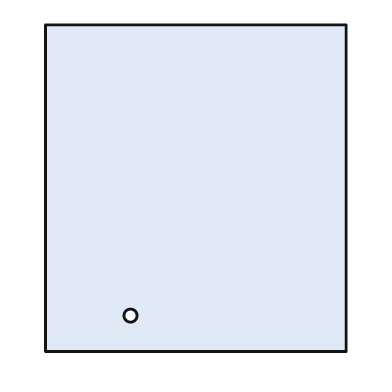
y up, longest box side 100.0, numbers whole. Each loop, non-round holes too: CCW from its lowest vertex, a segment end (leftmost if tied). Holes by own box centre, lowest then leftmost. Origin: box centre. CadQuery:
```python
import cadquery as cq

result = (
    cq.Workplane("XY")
    .moveTo(-46.0, -50.0)
    .lineTo(46.0, -50.0)
    .lineTo(46.0, 50.0)
    .lineTo(-46.0, 50.0)
    .close()
    .moveTo(-20.0, -39.0)
    .circle(2.0)
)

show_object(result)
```